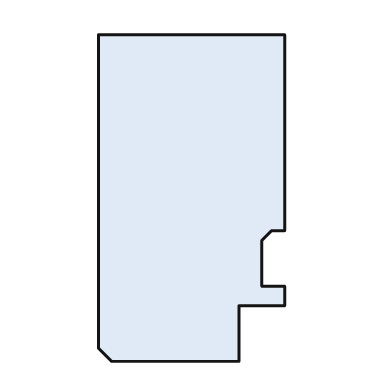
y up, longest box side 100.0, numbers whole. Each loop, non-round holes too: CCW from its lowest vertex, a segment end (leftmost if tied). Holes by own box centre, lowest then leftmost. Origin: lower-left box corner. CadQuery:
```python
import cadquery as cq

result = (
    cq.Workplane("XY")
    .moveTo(4.0, 0.0)
    .lineTo(43.0, 0.0)
    .lineTo(43.0, 17.0)
    .lineTo(57.0, 17.0)
    .lineTo(57.0, 23.0)
    .lineTo(50.0, 23.0)
    .lineTo(50.0, 37.0)
    .lineTo(53.0, 40.0)
    .lineTo(57.0, 40.0)
    .lineTo(57.0, 100.0)
    .lineTo(0.0, 100.0)
    .lineTo(0.0, 4.0)
    .close()
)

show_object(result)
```